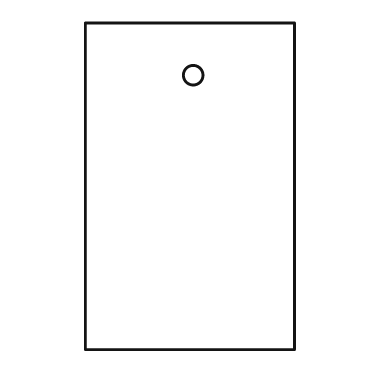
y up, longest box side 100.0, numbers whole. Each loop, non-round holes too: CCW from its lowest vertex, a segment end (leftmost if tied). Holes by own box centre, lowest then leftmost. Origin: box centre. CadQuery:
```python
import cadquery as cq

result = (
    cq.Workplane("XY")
    .moveTo(-32.0, -50.0)
    .lineTo(32.0, -50.0)
    .lineTo(32.0, 50.0)
    .lineTo(-32.0, 50.0)
    .close()
    .moveTo(1.0, 34.0)
    .circle(3.0)
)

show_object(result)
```